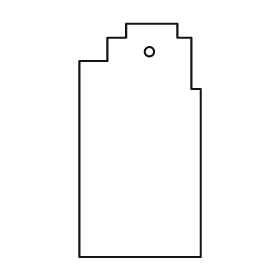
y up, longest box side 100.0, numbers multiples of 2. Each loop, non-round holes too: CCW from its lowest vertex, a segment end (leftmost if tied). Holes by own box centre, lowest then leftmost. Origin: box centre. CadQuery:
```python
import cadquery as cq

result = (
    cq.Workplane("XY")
    .moveTo(-26.0, -50.0)
    .lineTo(26.0, -50.0)
    .lineTo(26.0, 22.0)
    .lineTo(22.0, 22.0)
    .lineTo(22.0, 44.0)
    .lineTo(16.0, 44.0)
    .lineTo(16.0, 50.0)
    .lineTo(-6.0, 50.0)
    .lineTo(-6.0, 44.0)
    .lineTo(-14.0, 44.0)
    .lineTo(-14.0, 34.0)
    .lineTo(-26.0, 34.0)
    .close()
    .moveTo(4.0, 38.0)
    .circle(2.0)
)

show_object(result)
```